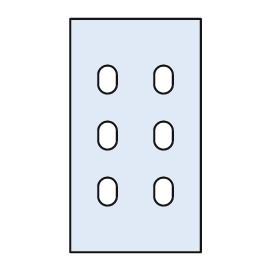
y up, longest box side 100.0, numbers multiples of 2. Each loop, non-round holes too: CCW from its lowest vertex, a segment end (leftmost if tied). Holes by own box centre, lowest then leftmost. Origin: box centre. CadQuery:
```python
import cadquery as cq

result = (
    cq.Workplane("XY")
    .moveTo(-28.0, -50.0)
    .lineTo(28.0, -50.0)
    .lineTo(28.0, 50.0)
    .lineTo(-28.0, 50.0)
    .close()
    .moveTo(-16.0, -26.0)
    .threePointArc((-12.0, -30.0), (-8.0, -26.0))
    .lineTo(-8.0, -22.0)
    .threePointArc((-12.0, -18.0), (-16.0, -22.0))
    .close()
    .moveTo(8.0, -26.0)
    .threePointArc((12.0, -30.0), (16.0, -26.0))
    .lineTo(16.0, -22.0)
    .threePointArc((12.0, -18.0), (8.0, -22.0))
    .close()
    .moveTo(-16.0, -2.0)
    .threePointArc((-12.0, -6.0), (-8.0, -2.0))
    .lineTo(-8.0, 2.0)
    .threePointArc((-12.0, 6.0), (-16.0, 2.0))
    .close()
    .moveTo(8.0, -2.0)
    .threePointArc((12.0, -6.0), (16.0, -2.0))
    .lineTo(16.0, 2.0)
    .threePointArc((12.0, 6.0), (8.0, 2.0))
    .close()
    .moveTo(-16.0, 22.0)
    .threePointArc((-12.0, 18.0), (-8.0, 22.0))
    .lineTo(-8.0, 26.0)
    .threePointArc((-12.0, 30.0), (-16.0, 26.0))
    .close()
    .moveTo(8.0, 22.0)
    .threePointArc((12.0, 18.0), (16.0, 22.0))
    .lineTo(16.0, 26.0)
    .threePointArc((12.0, 30.0), (8.0, 26.0))
    .close()
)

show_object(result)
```